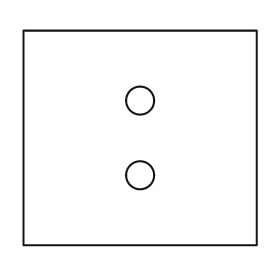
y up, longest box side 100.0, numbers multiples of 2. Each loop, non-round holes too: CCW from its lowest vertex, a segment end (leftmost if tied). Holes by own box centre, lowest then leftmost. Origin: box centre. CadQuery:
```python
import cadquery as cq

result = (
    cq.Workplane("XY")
    .moveTo(-50.0, -46.0)
    .lineTo(50.0, -46.0)
    .lineTo(50.0, 46.0)
    .lineTo(-50.0, 46.0)
    .close()
    .moveTo(0.0, -16.0)
    .circle(6.0)
    .moveTo(0.0, 16.0)
    .circle(6.0)
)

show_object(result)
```